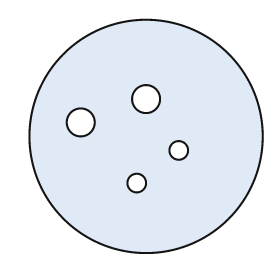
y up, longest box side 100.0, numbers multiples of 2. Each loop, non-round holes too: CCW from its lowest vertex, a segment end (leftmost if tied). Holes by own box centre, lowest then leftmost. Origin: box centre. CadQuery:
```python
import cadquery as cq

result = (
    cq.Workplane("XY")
    .moveTo(0.0, 0.0)
    .circle(50.0)
    .moveTo(-4.0, -20.0)
    .circle(4.0)
    .moveTo(14.0, -6.0)
    .circle(4.0)
    .moveTo(-28.0, 6.0)
    .circle(6.0)
    .moveTo(0.0, 16.0)
    .circle(6.0)
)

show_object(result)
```